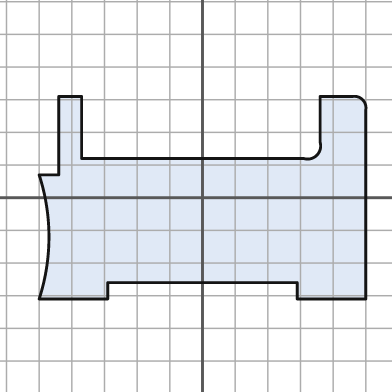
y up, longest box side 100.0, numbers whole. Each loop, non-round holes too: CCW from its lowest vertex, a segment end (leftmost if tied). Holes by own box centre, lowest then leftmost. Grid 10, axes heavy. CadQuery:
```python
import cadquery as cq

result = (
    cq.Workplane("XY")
    .moveTo(-50.0, -31.0)
    .lineTo(-29.0, -31.0)
    .lineTo(-29.0, -26.0)
    .lineTo(29.0, -26.0)
    .lineTo(29.0, -31.0)
    .lineTo(50.0, -31.0)
    .lineTo(50.0, 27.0)
    .threePointArc((49.0, 30.0), (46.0, 31.0))
    .lineTo(36.0, 31.0)
    .lineTo(36.0, 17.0)
    .threePointArc((35.0, 13.0), (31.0, 12.0))
    .lineTo(-37.0, 12.0)
    .lineTo(-37.0, 31.0)
    .lineTo(-44.0, 31.0)
    .lineTo(-44.0, 7.0)
    .lineTo(-50.0, 7.0)
    .threePointArc((-47.0, -12.0), (-50.0, -31.0))
    .close()
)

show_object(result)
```